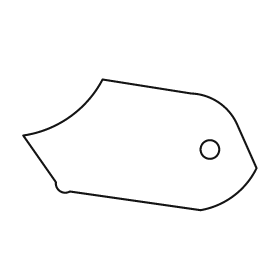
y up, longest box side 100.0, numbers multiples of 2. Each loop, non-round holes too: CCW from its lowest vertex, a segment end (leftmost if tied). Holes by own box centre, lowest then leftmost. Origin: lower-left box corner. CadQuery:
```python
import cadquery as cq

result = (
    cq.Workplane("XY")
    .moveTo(76.0, 0.0)
    .threePointArc((90.0, 6.0), (100.0, 18.0))
    .lineTo(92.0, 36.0)
    .threePointArc((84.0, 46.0), (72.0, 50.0))
    .lineTo(34.0, 56.0)
    .threePointArc((20.0, 40.0), (0.0, 32.0))
    .lineTo(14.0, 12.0)
    .threePointArc((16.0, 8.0), (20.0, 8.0))
    .close()
    .moveTo(80.0, 26.0)
    .circle(4.0)
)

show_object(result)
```